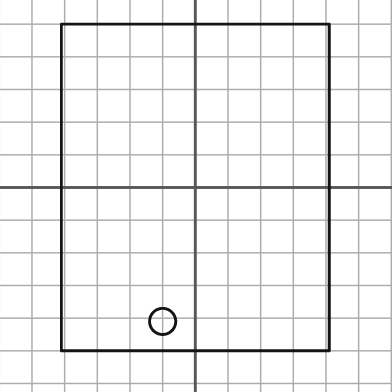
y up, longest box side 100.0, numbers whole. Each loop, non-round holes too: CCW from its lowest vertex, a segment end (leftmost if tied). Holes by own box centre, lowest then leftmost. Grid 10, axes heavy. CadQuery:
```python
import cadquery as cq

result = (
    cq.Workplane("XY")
    .moveTo(-41.0, -50.0)
    .lineTo(41.0, -50.0)
    .lineTo(41.0, 50.0)
    .lineTo(-41.0, 50.0)
    .close()
    .moveTo(-10.0, -41.0)
    .circle(4.0)
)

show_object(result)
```